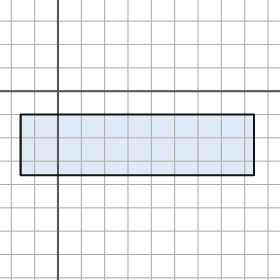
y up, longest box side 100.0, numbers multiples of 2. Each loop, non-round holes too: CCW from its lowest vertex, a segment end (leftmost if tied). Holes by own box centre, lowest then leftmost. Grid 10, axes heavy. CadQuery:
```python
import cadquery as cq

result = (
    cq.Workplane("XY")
    .moveTo(-16.0, -36.0)
    .lineTo(84.0, -36.0)
    .lineTo(84.0, -10.0)
    .lineTo(-16.0, -10.0)
    .close()
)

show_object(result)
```